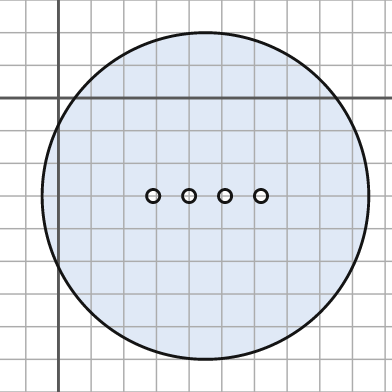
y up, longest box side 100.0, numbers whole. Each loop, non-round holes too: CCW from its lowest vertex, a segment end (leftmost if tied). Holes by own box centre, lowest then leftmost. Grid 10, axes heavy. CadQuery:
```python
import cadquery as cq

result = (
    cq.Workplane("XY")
    .moveTo(45.0, -30.0)
    .circle(50.0)
    .moveTo(29.0, -30.0)
    .circle(2.0)
    .moveTo(40.0, -30.0)
    .circle(2.0)
    .moveTo(51.0, -30.0)
    .circle(2.0)
    .moveTo(62.0, -30.0)
    .circle(2.0)
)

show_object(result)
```